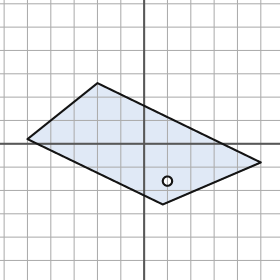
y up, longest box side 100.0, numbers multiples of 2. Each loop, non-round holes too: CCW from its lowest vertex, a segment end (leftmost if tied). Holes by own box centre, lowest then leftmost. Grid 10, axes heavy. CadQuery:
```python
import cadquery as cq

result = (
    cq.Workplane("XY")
    .moveTo(8.0, -26.0)
    .lineTo(50.0, -8.0)
    .lineTo(-20.0, 26.0)
    .lineTo(-50.0, 2.0)
    .close()
    .moveTo(10.0, -16.0)
    .circle(2.0)
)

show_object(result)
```